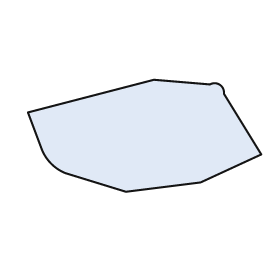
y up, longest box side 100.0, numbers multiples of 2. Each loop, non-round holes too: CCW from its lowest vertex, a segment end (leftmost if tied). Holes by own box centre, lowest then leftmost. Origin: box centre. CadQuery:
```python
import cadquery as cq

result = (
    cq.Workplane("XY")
    .moveTo(-8.0, -24.0)
    .lineTo(24.0, -20.0)
    .lineTo(50.0, -8.0)
    .lineTo(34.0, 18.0)
    .threePointArc((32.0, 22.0), (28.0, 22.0))
    .lineTo(4.0, 24.0)
    .lineTo(-50.0, 10.0)
    .lineTo(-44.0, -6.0)
    .threePointArc((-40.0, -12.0), (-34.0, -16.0))
    .close()
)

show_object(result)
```